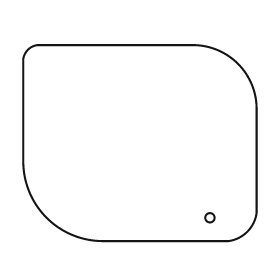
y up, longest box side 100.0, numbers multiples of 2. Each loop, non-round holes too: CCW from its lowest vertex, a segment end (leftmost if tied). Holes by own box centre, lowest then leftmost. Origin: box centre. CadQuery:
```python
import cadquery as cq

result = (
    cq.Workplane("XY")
    .moveTo(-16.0, -42.0)
    .lineTo(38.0, -42.0)
    .threePointArc((46.0, -38.0), (50.0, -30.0))
    .lineTo(50.0, 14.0)
    .threePointArc((42.0, 34.0), (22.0, 42.0))
    .lineTo(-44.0, 42.0)
    .threePointArc((-48.0, 40.0), (-50.0, 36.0))
    .lineTo(-50.0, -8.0)
    .threePointArc((-40.0, -32.0), (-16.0, -42.0))
    .close()
    .moveTo(30.0, -32.0)
    .circle(2.0)
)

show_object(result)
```